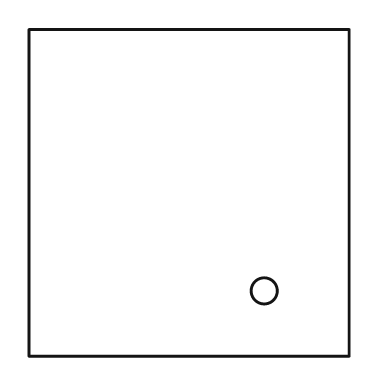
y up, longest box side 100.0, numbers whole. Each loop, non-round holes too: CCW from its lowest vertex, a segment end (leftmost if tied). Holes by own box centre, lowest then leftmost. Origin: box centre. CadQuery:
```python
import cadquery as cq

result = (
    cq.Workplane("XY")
    .moveTo(-49.0, -50.0)
    .lineTo(49.0, -50.0)
    .lineTo(49.0, 50.0)
    .lineTo(-49.0, 50.0)
    .close()
    .moveTo(23.0, -30.0)
    .circle(4.0)
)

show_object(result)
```